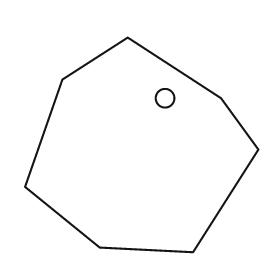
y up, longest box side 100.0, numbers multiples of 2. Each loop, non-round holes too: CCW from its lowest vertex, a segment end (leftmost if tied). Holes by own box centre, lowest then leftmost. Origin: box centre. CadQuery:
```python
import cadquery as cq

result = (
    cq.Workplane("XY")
    .moveTo(22.0, -46.0)
    .lineTo(50.0, -2.0)
    .lineTo(34.0, 20.0)
    .lineTo(-6.0, 46.0)
    .lineTo(-34.0, 28.0)
    .lineTo(-50.0, -18.0)
    .lineTo(-18.0, -44.0)
    .close()
    .moveTo(10.0, 20.0)
    .circle(4.0)
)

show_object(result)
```